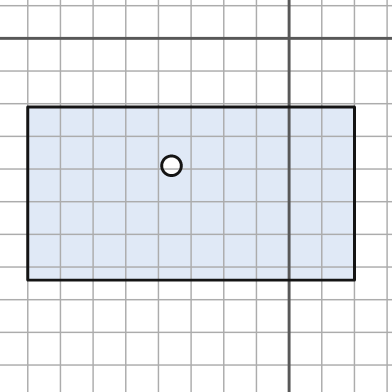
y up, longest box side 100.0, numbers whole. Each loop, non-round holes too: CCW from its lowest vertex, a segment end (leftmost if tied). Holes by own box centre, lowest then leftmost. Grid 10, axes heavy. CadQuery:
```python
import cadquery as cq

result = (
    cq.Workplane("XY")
    .moveTo(-80.0, -74.0)
    .lineTo(20.0, -74.0)
    .lineTo(20.0, -21.0)
    .lineTo(-80.0, -21.0)
    .close()
    .moveTo(-36.0, -39.0)
    .circle(3.0)
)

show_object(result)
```